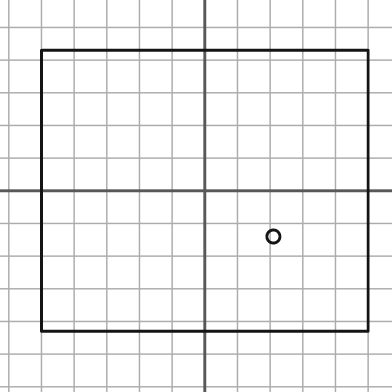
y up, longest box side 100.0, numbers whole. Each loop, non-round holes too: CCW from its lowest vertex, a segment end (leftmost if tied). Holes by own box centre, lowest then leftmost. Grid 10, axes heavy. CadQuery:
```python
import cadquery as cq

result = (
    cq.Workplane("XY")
    .moveTo(-50.0, -43.0)
    .lineTo(50.0, -43.0)
    .lineTo(50.0, 43.0)
    .lineTo(-50.0, 43.0)
    .close()
    .moveTo(21.0, -14.0)
    .circle(2.0)
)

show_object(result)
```